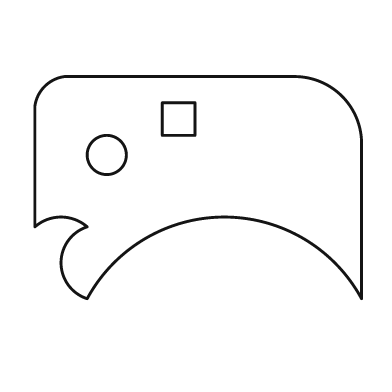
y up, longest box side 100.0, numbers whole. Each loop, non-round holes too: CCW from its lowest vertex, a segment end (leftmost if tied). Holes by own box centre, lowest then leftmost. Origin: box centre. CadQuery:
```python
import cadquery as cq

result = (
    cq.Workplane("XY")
    .moveTo(-34.0, -34.0)
    .threePointArc((8.0, -9.0), (50.0, -34.0))
    .lineTo(50.0, 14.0)
    .threePointArc((44.0, 28.0), (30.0, 34.0))
    .lineTo(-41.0, 34.0)
    .threePointArc((-47.0, 31.0), (-50.0, 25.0))
    .lineTo(-50.0, -12.0)
    .threePointArc((-42.0, -9.0), (-34.0, -12.0))
    .threePointArc((-42.0, -23.0), (-34.0, -34.0))
    .close()
    .moveTo(-28.0, 10.0)
    .circle(6.0)
    .moveTo(-11.0, 16.0)
    .lineTo(-1.0, 16.0)
    .lineTo(-1.0, 26.0)
    .lineTo(-11.0, 26.0)
    .close()
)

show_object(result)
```